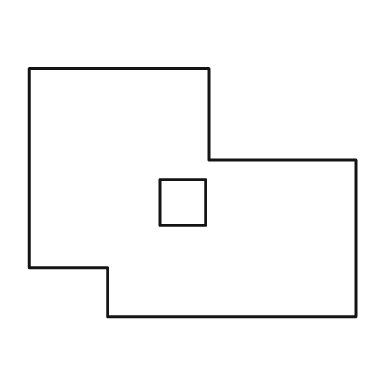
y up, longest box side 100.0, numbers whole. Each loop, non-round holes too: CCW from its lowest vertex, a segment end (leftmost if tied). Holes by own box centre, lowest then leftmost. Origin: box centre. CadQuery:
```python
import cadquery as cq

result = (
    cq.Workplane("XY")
    .moveTo(-26.0, -38.0)
    .lineTo(50.0, -38.0)
    .lineTo(50.0, 10.0)
    .lineTo(5.0, 10.0)
    .lineTo(5.0, 38.0)
    .lineTo(-50.0, 38.0)
    .lineTo(-50.0, -23.0)
    .lineTo(-26.0, -23.0)
    .close()
    .moveTo(-10.0, -10.0)
    .lineTo(4.0, -10.0)
    .lineTo(4.0, 4.0)
    .lineTo(-10.0, 4.0)
    .close()
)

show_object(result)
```